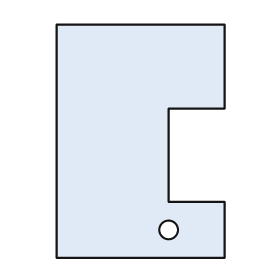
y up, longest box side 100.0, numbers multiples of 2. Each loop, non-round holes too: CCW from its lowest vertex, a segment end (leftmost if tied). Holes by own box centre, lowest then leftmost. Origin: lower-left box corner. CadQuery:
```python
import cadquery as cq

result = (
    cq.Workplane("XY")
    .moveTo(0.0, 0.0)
    .lineTo(72.0, 0.0)
    .lineTo(72.0, 24.0)
    .lineTo(48.0, 24.0)
    .lineTo(48.0, 64.0)
    .lineTo(72.0, 64.0)
    .lineTo(72.0, 100.0)
    .lineTo(0.0, 100.0)
    .close()
    .moveTo(48.0, 12.0)
    .circle(4.0)
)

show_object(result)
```